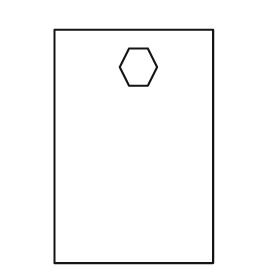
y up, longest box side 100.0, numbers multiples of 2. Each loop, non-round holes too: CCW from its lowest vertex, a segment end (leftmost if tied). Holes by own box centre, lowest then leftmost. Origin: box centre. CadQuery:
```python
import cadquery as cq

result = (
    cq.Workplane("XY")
    .moveTo(-34.0, -50.0)
    .lineTo(34.0, -50.0)
    .lineTo(34.0, 50.0)
    .lineTo(-34.0, 50.0)
    .close()
    .moveTo(-2.0, 26.0)
    .lineTo(6.0, 26.0)
    .lineTo(10.0, 34.0)
    .lineTo(6.0, 42.0)
    .lineTo(-2.0, 42.0)
    .lineTo(-6.0, 34.0)
    .close()
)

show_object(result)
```